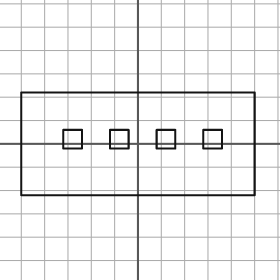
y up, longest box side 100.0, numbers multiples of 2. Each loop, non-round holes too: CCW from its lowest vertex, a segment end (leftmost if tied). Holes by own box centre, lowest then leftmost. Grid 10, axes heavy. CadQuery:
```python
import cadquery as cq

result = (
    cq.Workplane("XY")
    .moveTo(-50.0, -22.0)
    .lineTo(50.0, -22.0)
    .lineTo(50.0, 22.0)
    .lineTo(-50.0, 22.0)
    .close()
    .moveTo(-32.0, -2.0)
    .lineTo(-24.0, -2.0)
    .lineTo(-24.0, 6.0)
    .lineTo(-32.0, 6.0)
    .close()
    .moveTo(-12.0, -2.0)
    .lineTo(-4.0, -2.0)
    .lineTo(-4.0, 6.0)
    .lineTo(-12.0, 6.0)
    .close()
    .moveTo(8.0, -2.0)
    .lineTo(16.0, -2.0)
    .lineTo(16.0, 6.0)
    .lineTo(8.0, 6.0)
    .close()
    .moveTo(28.0, -2.0)
    .lineTo(36.0, -2.0)
    .lineTo(36.0, 6.0)
    .lineTo(28.0, 6.0)
    .close()
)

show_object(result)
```